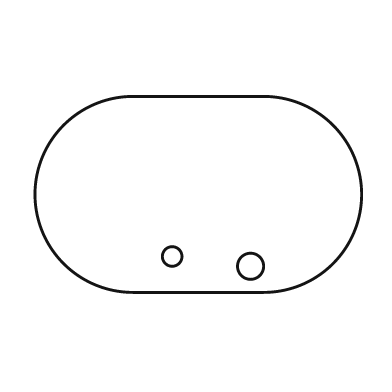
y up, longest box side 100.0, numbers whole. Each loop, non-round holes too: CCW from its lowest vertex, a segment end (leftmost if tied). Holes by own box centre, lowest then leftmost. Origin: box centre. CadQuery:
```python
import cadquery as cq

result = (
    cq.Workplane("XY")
    .moveTo(-20.0, -30.0)
    .lineTo(20.0, -30.0)
    .threePointArc((50.0, 0.0), (20.0, 30.0))
    .lineTo(-20.0, 30.0)
    .threePointArc((-50.0, 0.0), (-20.0, -30.0))
    .close()
    .moveTo(16.0, -22.0)
    .circle(4.0)
    .moveTo(-8.0, -19.0)
    .circle(3.0)
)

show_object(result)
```